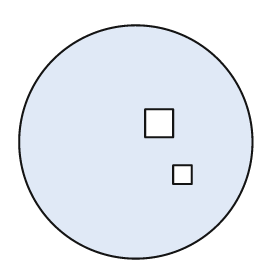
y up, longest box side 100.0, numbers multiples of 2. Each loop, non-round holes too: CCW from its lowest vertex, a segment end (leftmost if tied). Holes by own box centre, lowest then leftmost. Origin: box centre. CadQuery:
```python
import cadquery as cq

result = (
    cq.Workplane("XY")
    .moveTo(0.0, 0.0)
    .circle(50.0)
    .moveTo(16.0, -18.0)
    .lineTo(24.0, -18.0)
    .lineTo(24.0, -10.0)
    .lineTo(16.0, -10.0)
    .close()
    .moveTo(4.0, 2.0)
    .lineTo(16.0, 2.0)
    .lineTo(16.0, 14.0)
    .lineTo(4.0, 14.0)
    .close()
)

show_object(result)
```